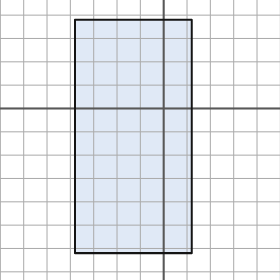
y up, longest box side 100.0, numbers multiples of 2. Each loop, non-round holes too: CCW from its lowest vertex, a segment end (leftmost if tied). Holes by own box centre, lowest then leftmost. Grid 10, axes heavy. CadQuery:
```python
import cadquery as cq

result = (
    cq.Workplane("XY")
    .moveTo(-38.0, -62.0)
    .lineTo(12.0, -62.0)
    .lineTo(12.0, 38.0)
    .lineTo(-38.0, 38.0)
    .close()
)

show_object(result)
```